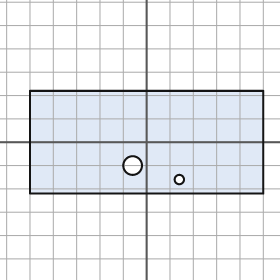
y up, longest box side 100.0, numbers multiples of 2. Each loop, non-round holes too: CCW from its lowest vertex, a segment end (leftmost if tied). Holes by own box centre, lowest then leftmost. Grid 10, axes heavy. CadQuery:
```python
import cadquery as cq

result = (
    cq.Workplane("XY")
    .moveTo(-50.0, -22.0)
    .lineTo(50.0, -22.0)
    .lineTo(50.0, 22.0)
    .lineTo(-50.0, 22.0)
    .close()
    .moveTo(14.0, -16.0)
    .circle(2.0)
    .moveTo(-6.0, -10.0)
    .circle(4.0)
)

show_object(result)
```